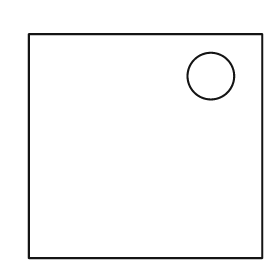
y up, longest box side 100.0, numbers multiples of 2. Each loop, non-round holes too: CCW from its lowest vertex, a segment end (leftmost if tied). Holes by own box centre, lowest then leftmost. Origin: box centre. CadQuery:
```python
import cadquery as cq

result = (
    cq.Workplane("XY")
    .moveTo(-50.0, -48.0)
    .lineTo(50.0, -48.0)
    .lineTo(50.0, 48.0)
    .lineTo(-50.0, 48.0)
    .close()
    .moveTo(28.0, 30.0)
    .circle(10.0)
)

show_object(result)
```